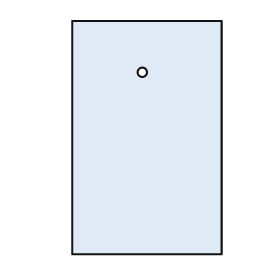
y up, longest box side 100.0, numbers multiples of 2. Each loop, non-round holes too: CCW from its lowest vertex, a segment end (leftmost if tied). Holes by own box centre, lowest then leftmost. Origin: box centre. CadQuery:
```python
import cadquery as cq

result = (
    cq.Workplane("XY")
    .moveTo(-32.0, -50.0)
    .lineTo(32.0, -50.0)
    .lineTo(32.0, 50.0)
    .lineTo(-32.0, 50.0)
    .close()
    .moveTo(-2.0, 28.0)
    .circle(2.0)
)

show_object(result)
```